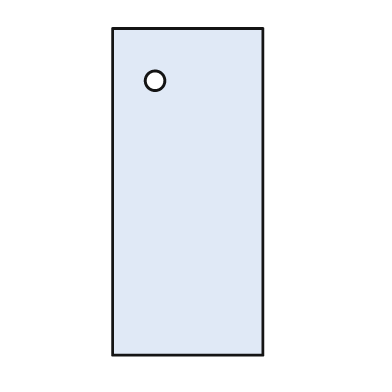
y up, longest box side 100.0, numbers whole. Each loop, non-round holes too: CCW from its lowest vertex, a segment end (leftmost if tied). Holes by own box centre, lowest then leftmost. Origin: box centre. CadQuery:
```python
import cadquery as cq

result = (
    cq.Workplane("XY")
    .moveTo(-23.0, -50.0)
    .lineTo(23.0, -50.0)
    .lineTo(23.0, 50.0)
    .lineTo(-23.0, 50.0)
    .close()
    .moveTo(-10.0, 34.0)
    .circle(3.0)
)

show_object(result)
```